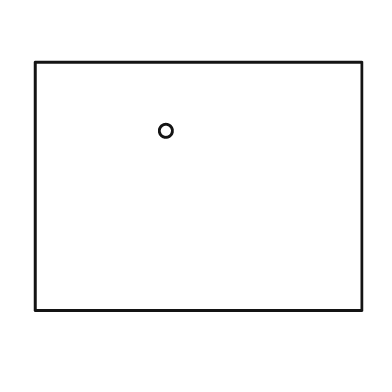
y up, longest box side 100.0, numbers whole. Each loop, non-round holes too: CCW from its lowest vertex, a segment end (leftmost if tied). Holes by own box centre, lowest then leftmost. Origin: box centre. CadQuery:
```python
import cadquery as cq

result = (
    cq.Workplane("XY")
    .moveTo(-50.0, -38.0)
    .lineTo(50.0, -38.0)
    .lineTo(50.0, 38.0)
    .lineTo(-50.0, 38.0)
    .close()
    .moveTo(-10.0, 17.0)
    .circle(2.0)
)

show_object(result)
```